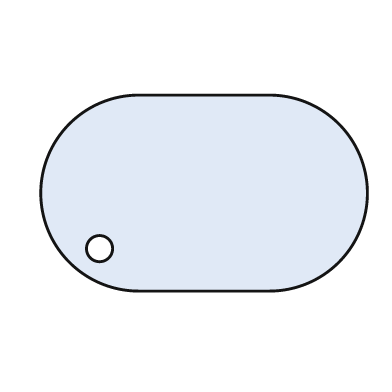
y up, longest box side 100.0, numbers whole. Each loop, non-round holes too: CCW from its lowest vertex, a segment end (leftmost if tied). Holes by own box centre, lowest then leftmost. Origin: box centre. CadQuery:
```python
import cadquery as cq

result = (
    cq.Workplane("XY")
    .moveTo(-20.0, -30.0)
    .lineTo(20.0, -30.0)
    .threePointArc((50.0, 0.0), (20.0, 30.0))
    .lineTo(-20.0, 30.0)
    .threePointArc((-50.0, 0.0), (-20.0, -30.0))
    .close()
    .moveTo(-32.0, -17.0)
    .circle(4.0)
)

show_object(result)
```